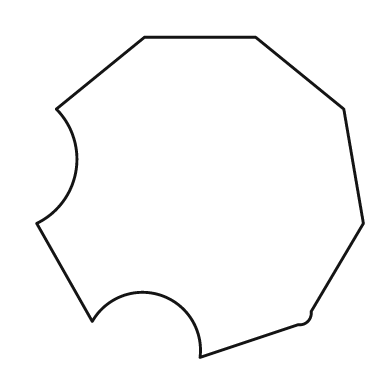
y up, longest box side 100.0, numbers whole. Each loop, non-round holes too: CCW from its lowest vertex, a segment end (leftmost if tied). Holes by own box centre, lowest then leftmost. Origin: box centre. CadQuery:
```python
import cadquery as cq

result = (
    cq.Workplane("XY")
    .moveTo(0.0, -49.0)
    .lineTo(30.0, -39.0)
    .threePointArc((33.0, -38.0), (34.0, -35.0))
    .lineTo(50.0, -8.0)
    .lineTo(44.0, 27.0)
    .lineTo(17.0, 49.0)
    .lineTo(-17.0, 49.0)
    .lineTo(-44.0, 27.0)
    .threePointArc((-38.0, 8.0), (-50.0, -8.0))
    .lineTo(-33.0, -38.0)
    .threePointArc((-12.0, -30.0), (0.0, -49.0))
    .close()
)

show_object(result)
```